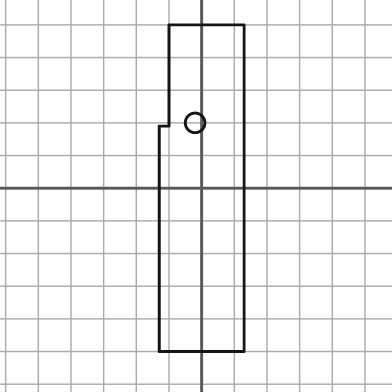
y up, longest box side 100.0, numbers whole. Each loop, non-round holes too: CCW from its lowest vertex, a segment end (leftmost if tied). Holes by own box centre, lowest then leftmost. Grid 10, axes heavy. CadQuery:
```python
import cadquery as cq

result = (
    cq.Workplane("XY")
    .moveTo(-13.0, -50.0)
    .lineTo(13.0, -50.0)
    .lineTo(13.0, 50.0)
    .lineTo(-10.0, 50.0)
    .lineTo(-10.0, 19.0)
    .lineTo(-13.0, 19.0)
    .close()
    .moveTo(-2.0, 20.0)
    .circle(3.0)
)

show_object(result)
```